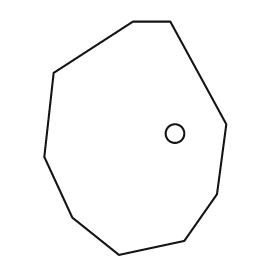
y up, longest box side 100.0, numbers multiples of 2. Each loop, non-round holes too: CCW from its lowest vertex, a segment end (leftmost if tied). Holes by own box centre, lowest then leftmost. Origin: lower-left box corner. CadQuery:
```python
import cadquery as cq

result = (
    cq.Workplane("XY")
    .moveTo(32.0, 0.0)
    .lineTo(60.0, 6.0)
    .lineTo(74.0, 26.0)
    .lineTo(78.0, 56.0)
    .lineTo(54.0, 100.0)
    .lineTo(38.0, 100.0)
    .lineTo(4.0, 78.0)
    .lineTo(0.0, 42.0)
    .lineTo(12.0, 16.0)
    .close()
    .moveTo(56.0, 52.0)
    .circle(4.0)
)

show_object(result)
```